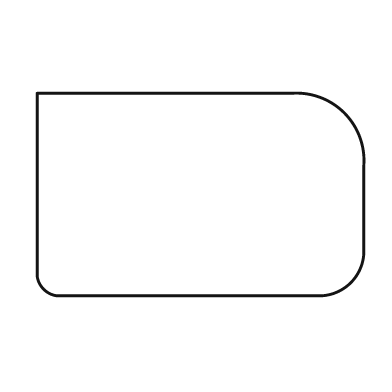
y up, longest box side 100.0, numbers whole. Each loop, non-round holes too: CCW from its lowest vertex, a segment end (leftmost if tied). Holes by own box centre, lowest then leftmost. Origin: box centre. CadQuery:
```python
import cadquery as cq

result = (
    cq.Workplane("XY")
    .moveTo(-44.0, -31.0)
    .lineTo(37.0, -31.0)
    .threePointArc((46.0, -27.0), (50.0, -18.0))
    .lineTo(50.0, 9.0)
    .threePointArc((44.0, 25.0), (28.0, 31.0))
    .lineTo(-50.0, 31.0)
    .lineTo(-50.0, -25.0)
    .threePointArc((-48.0, -29.0), (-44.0, -31.0))
    .close()
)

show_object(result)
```